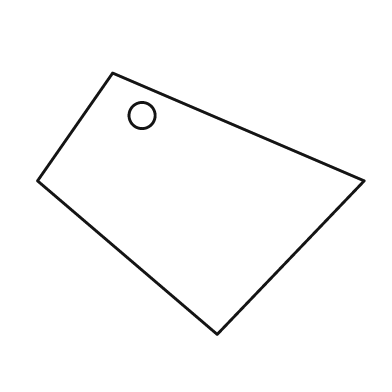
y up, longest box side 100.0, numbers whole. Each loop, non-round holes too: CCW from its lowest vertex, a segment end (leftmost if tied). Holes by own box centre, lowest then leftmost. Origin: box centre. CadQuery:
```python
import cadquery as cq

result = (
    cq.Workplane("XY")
    .moveTo(5.0, -40.0)
    .lineTo(50.0, 7.0)
    .lineTo(-27.0, 40.0)
    .lineTo(-50.0, 7.0)
    .close()
    .moveTo(-18.0, 27.0)
    .circle(4.0)
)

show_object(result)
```